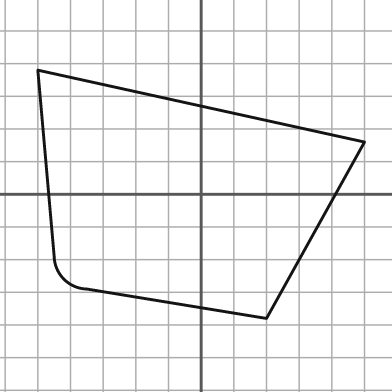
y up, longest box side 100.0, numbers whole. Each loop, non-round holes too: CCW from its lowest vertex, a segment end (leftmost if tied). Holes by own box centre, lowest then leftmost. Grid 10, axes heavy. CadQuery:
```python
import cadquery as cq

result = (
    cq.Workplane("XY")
    .moveTo(20.0, -38.0)
    .lineTo(50.0, 16.0)
    .lineTo(-50.0, 38.0)
    .lineTo(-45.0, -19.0)
    .threePointArc((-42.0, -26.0), (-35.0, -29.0))
    .close()
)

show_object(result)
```